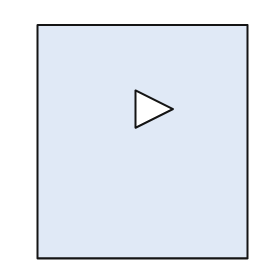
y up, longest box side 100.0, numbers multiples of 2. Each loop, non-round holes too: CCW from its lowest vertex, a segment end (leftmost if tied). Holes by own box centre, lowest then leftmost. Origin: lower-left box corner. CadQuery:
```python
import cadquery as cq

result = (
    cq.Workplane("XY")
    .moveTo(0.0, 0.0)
    .lineTo(90.0, 0.0)
    .lineTo(90.0, 100.0)
    .lineTo(0.0, 100.0)
    .close()
    .moveTo(42.0, 56.0)
    .lineTo(58.0, 64.0)
    .lineTo(42.0, 72.0)
    .close()
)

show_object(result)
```